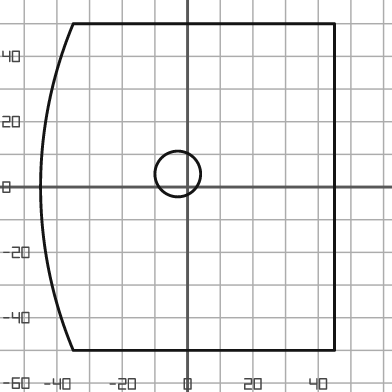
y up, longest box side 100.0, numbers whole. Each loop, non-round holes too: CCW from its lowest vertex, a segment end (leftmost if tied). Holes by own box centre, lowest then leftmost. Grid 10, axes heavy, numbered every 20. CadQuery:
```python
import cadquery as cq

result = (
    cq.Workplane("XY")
    .moveTo(-35.0, -50.0)
    .lineTo(45.0, -50.0)
    .lineTo(45.0, 50.0)
    .lineTo(-35.0, 50.0)
    .threePointArc((-45.0, 0.0), (-35.0, -50.0))
    .close()
    .moveTo(-3.0, 4.0)
    .circle(7.0)
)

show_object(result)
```